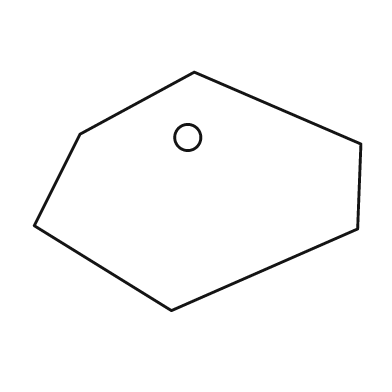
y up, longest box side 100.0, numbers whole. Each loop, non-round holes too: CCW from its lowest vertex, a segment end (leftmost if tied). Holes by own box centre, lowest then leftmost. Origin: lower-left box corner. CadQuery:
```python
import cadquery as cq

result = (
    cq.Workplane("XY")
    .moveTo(42.0, 0.0)
    .lineTo(99.0, 25.0)
    .lineTo(100.0, 51.0)
    .lineTo(49.0, 73.0)
    .lineTo(14.0, 54.0)
    .lineTo(0.0, 26.0)
    .close()
    .moveTo(47.0, 53.0)
    .circle(4.0)
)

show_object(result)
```